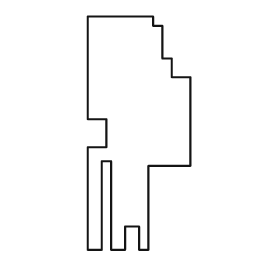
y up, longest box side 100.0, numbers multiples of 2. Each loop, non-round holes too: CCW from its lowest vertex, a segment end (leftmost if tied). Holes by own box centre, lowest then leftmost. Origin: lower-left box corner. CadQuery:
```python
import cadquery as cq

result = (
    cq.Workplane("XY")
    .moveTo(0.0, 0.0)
    .lineTo(6.0, 0.0)
    .lineTo(6.0, 38.0)
    .lineTo(10.0, 38.0)
    .lineTo(10.0, 0.0)
    .lineTo(16.0, 0.0)
    .lineTo(16.0, 10.0)
    .lineTo(22.0, 10.0)
    .lineTo(22.0, 0.0)
    .lineTo(26.0, 0.0)
    .lineTo(26.0, 36.0)
    .lineTo(44.0, 36.0)
    .lineTo(44.0, 74.0)
    .lineTo(36.0, 74.0)
    .lineTo(36.0, 82.0)
    .lineTo(32.0, 82.0)
    .lineTo(32.0, 96.0)
    .lineTo(28.0, 96.0)
    .lineTo(28.0, 100.0)
    .lineTo(0.0, 100.0)
    .lineTo(0.0, 56.0)
    .lineTo(8.0, 56.0)
    .lineTo(8.0, 44.0)
    .lineTo(0.0, 44.0)
    .close()
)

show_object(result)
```